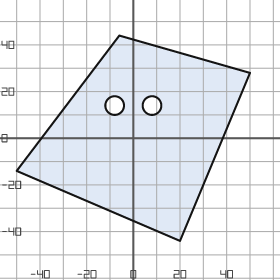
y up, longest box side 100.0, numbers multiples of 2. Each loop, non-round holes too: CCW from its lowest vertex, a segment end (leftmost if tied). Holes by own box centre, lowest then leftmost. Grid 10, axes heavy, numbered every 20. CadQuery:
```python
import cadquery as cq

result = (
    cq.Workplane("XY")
    .moveTo(20.0, -44.0)
    .lineTo(50.0, 28.0)
    .lineTo(-6.0, 44.0)
    .lineTo(-50.0, -14.0)
    .close()
    .moveTo(-8.0, 14.0)
    .circle(4.0)
    .moveTo(8.0, 14.0)
    .circle(4.0)
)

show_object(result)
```